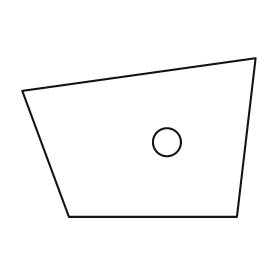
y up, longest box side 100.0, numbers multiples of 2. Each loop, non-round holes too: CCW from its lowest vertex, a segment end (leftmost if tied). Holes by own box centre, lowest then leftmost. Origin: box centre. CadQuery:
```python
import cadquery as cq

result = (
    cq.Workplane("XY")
    .moveTo(-30.0, -34.0)
    .lineTo(42.0, -34.0)
    .lineTo(50.0, 34.0)
    .lineTo(-50.0, 20.0)
    .close()
    .moveTo(12.0, -2.0)
    .circle(6.0)
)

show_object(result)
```